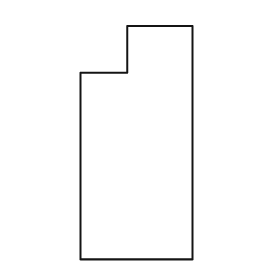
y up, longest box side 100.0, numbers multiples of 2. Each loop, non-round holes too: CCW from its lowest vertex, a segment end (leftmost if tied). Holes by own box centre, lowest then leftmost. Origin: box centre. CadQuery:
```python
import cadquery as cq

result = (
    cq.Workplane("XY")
    .moveTo(-24.0, -50.0)
    .lineTo(24.0, -50.0)
    .lineTo(24.0, 50.0)
    .lineTo(-4.0, 50.0)
    .lineTo(-4.0, 30.0)
    .lineTo(-24.0, 30.0)
    .close()
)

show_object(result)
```